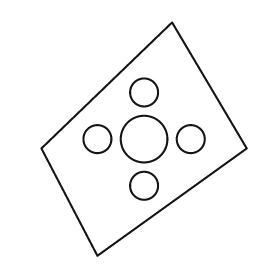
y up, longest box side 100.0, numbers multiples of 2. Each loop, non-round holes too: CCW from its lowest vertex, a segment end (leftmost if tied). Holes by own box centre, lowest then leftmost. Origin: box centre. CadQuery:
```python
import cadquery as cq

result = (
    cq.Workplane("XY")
    .moveTo(-20.0, -50.0)
    .lineTo(44.0, -4.0)
    .lineTo(12.0, 50.0)
    .lineTo(-44.0, -4.0)
    .close()
    .moveTo(0.0, -20.0)
    .circle(6.0)
    .moveTo(-20.0, 0.0)
    .circle(6.0)
    .moveTo(0.0, 0.0)
    .circle(10.0)
    .moveTo(20.0, 0.0)
    .circle(6.0)
    .moveTo(0.0, 20.0)
    .circle(6.0)
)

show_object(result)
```